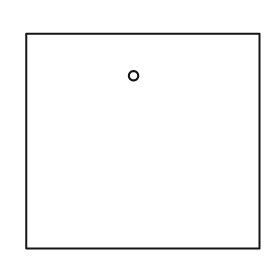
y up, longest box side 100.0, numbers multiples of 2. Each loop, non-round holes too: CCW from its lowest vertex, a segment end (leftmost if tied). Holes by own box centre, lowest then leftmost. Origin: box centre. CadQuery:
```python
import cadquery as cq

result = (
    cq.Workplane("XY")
    .moveTo(-50.0, -46.0)
    .lineTo(50.0, -46.0)
    .lineTo(50.0, 46.0)
    .lineTo(-50.0, 46.0)
    .close()
    .moveTo(-4.0, 28.0)
    .circle(2.0)
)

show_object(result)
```